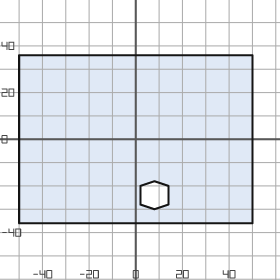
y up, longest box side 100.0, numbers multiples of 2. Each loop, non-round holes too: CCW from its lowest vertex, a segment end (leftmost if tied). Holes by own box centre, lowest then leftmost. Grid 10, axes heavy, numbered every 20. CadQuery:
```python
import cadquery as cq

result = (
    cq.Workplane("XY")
    .moveTo(-50.0, -36.0)
    .lineTo(50.0, -36.0)
    .lineTo(50.0, 36.0)
    .lineTo(-50.0, 36.0)
    .close()
    .moveTo(8.0, -30.0)
    .lineTo(14.0, -28.0)
    .lineTo(14.0, -20.0)
    .lineTo(8.0, -18.0)
    .lineTo(2.0, -20.0)
    .lineTo(2.0, -28.0)
    .close()
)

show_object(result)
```